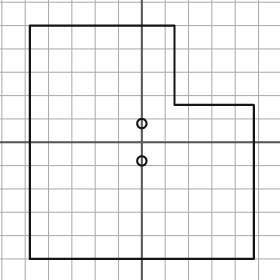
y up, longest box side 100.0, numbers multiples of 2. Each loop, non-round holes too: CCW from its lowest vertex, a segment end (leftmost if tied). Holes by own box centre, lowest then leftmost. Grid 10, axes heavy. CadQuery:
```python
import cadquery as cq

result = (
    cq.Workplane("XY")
    .moveTo(-48.0, -50.0)
    .lineTo(48.0, -50.0)
    .lineTo(48.0, 16.0)
    .lineTo(14.0, 16.0)
    .lineTo(14.0, 50.0)
    .lineTo(-48.0, 50.0)
    .close()
    .moveTo(0.0, -8.0)
    .circle(2.0)
    .moveTo(0.0, 8.0)
    .circle(2.0)
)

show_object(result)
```